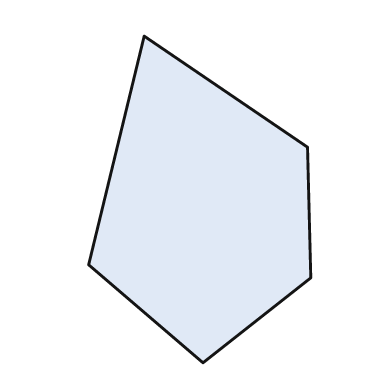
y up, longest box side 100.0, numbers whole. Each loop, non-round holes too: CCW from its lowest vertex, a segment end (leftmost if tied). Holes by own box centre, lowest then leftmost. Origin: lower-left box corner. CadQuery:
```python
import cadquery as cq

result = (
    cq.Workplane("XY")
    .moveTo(35.0, 0.0)
    .lineTo(68.0, 26.0)
    .lineTo(67.0, 66.0)
    .lineTo(17.0, 100.0)
    .lineTo(0.0, 30.0)
    .close()
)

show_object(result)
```